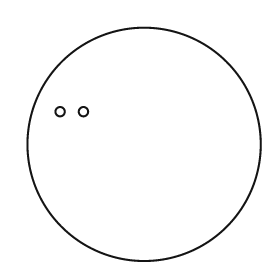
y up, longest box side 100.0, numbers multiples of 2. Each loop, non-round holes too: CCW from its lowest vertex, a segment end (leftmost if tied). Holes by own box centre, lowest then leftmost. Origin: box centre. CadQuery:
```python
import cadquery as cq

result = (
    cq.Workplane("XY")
    .moveTo(0.0, 0.0)
    .circle(50.0)
    .moveTo(-36.0, 14.0)
    .circle(2.0)
    .moveTo(-26.0, 14.0)
    .circle(2.0)
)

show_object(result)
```